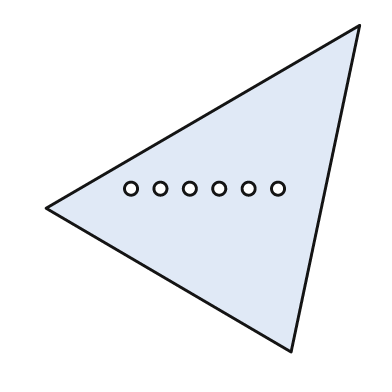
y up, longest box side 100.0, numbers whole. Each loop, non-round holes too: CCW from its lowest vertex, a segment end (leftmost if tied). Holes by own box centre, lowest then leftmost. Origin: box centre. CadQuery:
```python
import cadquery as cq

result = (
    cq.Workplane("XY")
    .moveTo(27.0, -50.0)
    .lineTo(48.0, 50.0)
    .lineTo(-48.0, -6.0)
    .close()
    .moveTo(-22.0, 0.0)
    .circle(2.0)
    .moveTo(-13.0, 0.0)
    .circle(2.0)
    .moveTo(-4.0, 0.0)
    .circle(2.0)
    .moveTo(5.0, 0.0)
    .circle(2.0)
    .moveTo(14.0, 0.0)
    .circle(2.0)
    .moveTo(23.0, 0.0)
    .circle(2.0)
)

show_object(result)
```